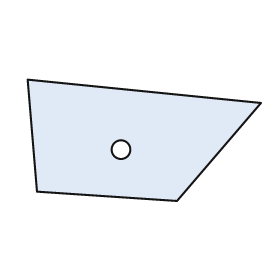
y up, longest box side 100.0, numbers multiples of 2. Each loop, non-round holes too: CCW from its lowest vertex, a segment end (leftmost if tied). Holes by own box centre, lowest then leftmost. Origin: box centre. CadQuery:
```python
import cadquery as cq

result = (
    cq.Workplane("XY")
    .moveTo(14.0, -26.0)
    .lineTo(50.0, 16.0)
    .lineTo(-50.0, 26.0)
    .lineTo(-46.0, -22.0)
    .close()
    .moveTo(-10.0, -4.0)
    .circle(4.0)
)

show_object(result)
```